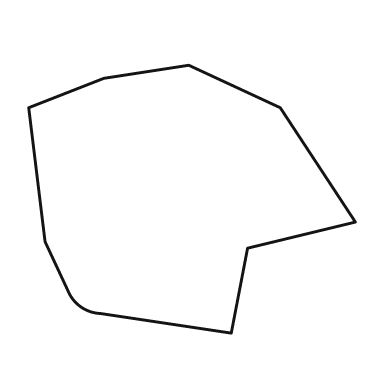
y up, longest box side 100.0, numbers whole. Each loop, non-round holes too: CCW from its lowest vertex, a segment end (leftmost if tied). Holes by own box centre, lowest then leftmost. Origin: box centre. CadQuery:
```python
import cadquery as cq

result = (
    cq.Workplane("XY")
    .moveTo(12.0, -41.0)
    .lineTo(17.0, -15.0)
    .lineTo(50.0, -7.0)
    .lineTo(27.0, 28.0)
    .lineTo(-1.0, 41.0)
    .lineTo(-27.0, 37.0)
    .lineTo(-50.0, 28.0)
    .lineTo(-45.0, -13.0)
    .lineTo(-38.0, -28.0)
    .threePointArc((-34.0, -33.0), (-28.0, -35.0))
    .close()
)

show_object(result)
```